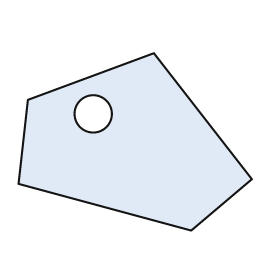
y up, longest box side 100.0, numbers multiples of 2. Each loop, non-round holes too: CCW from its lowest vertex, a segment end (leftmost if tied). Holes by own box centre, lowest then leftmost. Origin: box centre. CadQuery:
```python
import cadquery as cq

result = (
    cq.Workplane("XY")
    .moveTo(24.0, -38.0)
    .lineTo(50.0, -16.0)
    .lineTo(8.0, 38.0)
    .lineTo(-46.0, 18.0)
    .lineTo(-50.0, -18.0)
    .close()
    .moveTo(-18.0, 12.0)
    .circle(8.0)
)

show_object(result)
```